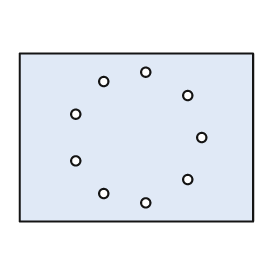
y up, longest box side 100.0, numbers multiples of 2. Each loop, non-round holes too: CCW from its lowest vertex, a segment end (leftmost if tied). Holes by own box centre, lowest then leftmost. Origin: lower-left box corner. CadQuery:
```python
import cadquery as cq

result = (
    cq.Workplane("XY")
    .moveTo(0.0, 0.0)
    .lineTo(100.0, 0.0)
    .lineTo(100.0, 72.0)
    .lineTo(0.0, 72.0)
    .close()
    .moveTo(54.0, 8.0)
    .circle(2.0)
    .moveTo(36.0, 12.0)
    .circle(2.0)
    .moveTo(72.0, 18.0)
    .circle(2.0)
    .moveTo(24.0, 26.0)
    .circle(2.0)
    .moveTo(78.0, 36.0)
    .circle(2.0)
    .moveTo(24.0, 46.0)
    .circle(2.0)
    .moveTo(72.0, 54.0)
    .circle(2.0)
    .moveTo(36.0, 60.0)
    .circle(2.0)
    .moveTo(54.0, 64.0)
    .circle(2.0)
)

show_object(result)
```